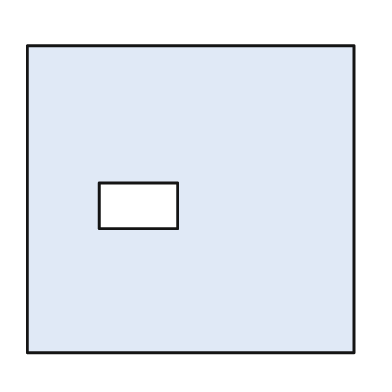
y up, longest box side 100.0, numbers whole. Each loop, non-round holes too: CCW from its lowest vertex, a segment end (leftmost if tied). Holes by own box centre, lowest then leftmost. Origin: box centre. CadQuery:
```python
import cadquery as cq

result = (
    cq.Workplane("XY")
    .moveTo(-50.0, -47.0)
    .lineTo(50.0, -47.0)
    .lineTo(50.0, 47.0)
    .lineTo(-50.0, 47.0)
    .close()
    .moveTo(-28.0, -9.0)
    .lineTo(-4.0, -9.0)
    .lineTo(-4.0, 5.0)
    .lineTo(-28.0, 5.0)
    .close()
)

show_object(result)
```